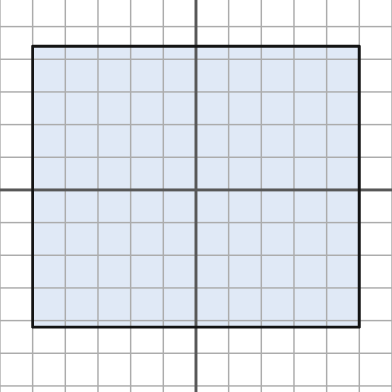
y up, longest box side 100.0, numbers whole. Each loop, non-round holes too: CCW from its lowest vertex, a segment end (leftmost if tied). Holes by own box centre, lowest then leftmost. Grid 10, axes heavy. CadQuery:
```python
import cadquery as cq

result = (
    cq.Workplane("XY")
    .moveTo(-50.0, -42.0)
    .lineTo(50.0, -42.0)
    .lineTo(50.0, 44.0)
    .lineTo(-50.0, 44.0)
    .close()
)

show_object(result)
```